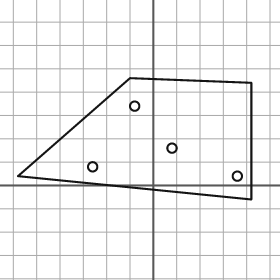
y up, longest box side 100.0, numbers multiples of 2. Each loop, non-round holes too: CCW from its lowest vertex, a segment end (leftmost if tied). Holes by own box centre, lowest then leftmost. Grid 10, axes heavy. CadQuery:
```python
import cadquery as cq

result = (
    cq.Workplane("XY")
    .moveTo(42.0, -6.0)
    .lineTo(42.0, 44.0)
    .lineTo(-10.0, 46.0)
    .lineTo(-58.0, 4.0)
    .close()
    .moveTo(36.0, 4.0)
    .circle(2.0)
    .moveTo(-26.0, 8.0)
    .circle(2.0)
    .moveTo(8.0, 16.0)
    .circle(2.0)
    .moveTo(-8.0, 34.0)
    .circle(2.0)
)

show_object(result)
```